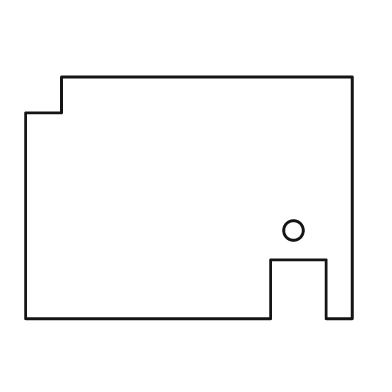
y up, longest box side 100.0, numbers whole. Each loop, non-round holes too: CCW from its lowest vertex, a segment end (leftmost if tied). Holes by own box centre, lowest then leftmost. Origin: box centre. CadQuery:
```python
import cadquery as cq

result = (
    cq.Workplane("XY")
    .moveTo(-50.0, -37.0)
    .lineTo(25.0, -37.0)
    .lineTo(25.0, -19.0)
    .lineTo(42.0, -19.0)
    .lineTo(42.0, -37.0)
    .lineTo(50.0, -37.0)
    .lineTo(50.0, 37.0)
    .lineTo(-39.0, 37.0)
    .lineTo(-39.0, 26.0)
    .lineTo(-50.0, 26.0)
    .close()
    .moveTo(32.0, -10.0)
    .circle(3.0)
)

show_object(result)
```